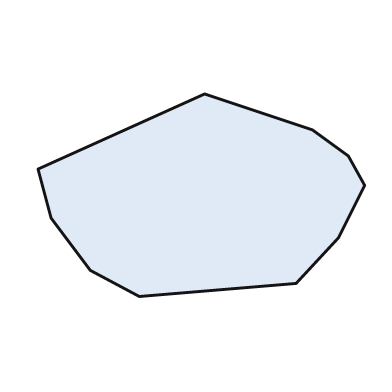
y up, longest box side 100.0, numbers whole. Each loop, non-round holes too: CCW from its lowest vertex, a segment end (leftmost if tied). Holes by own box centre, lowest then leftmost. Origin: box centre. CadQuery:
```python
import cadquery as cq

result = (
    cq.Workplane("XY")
    .moveTo(-19.0, -31.0)
    .lineTo(29.0, -27.0)
    .lineTo(42.0, -13.0)
    .lineTo(50.0, 3.0)
    .lineTo(45.0, 12.0)
    .lineTo(34.0, 20.0)
    .lineTo(1.0, 31.0)
    .lineTo(-50.0, 8.0)
    .lineTo(-46.0, -7.0)
    .lineTo(-34.0, -23.0)
    .close()
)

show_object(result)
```